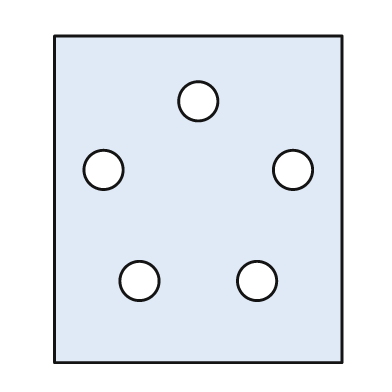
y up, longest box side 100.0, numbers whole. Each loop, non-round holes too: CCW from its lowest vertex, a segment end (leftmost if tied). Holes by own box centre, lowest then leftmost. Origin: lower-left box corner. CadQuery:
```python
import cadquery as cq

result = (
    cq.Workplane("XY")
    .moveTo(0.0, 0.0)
    .lineTo(88.0, 0.0)
    .lineTo(88.0, 100.0)
    .lineTo(0.0, 100.0)
    .close()
    .moveTo(26.0, 25.0)
    .circle(6.0)
    .moveTo(62.0, 25.0)
    .circle(6.0)
    .moveTo(15.0, 59.0)
    .circle(6.0)
    .moveTo(73.0, 59.0)
    .circle(6.0)
    .moveTo(44.0, 80.0)
    .circle(6.0)
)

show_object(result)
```